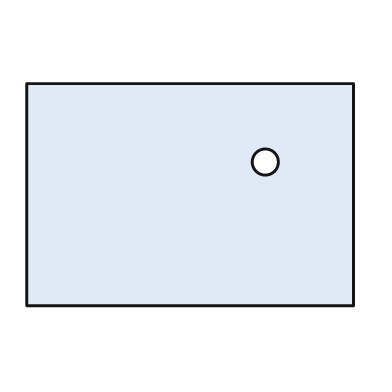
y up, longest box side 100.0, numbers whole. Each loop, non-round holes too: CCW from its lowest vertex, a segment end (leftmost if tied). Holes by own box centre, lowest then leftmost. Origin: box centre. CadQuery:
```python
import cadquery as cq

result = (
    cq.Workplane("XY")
    .moveTo(-50.0, -34.0)
    .lineTo(50.0, -34.0)
    .lineTo(50.0, 34.0)
    .lineTo(-50.0, 34.0)
    .close()
    .moveTo(23.0, 10.0)
    .circle(4.0)
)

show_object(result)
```